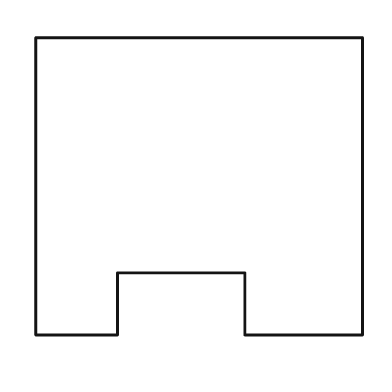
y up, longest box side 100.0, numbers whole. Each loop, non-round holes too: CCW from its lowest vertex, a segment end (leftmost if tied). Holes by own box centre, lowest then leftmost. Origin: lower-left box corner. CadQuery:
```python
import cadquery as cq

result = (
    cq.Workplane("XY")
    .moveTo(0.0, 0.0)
    .lineTo(25.0, 0.0)
    .lineTo(25.0, 19.0)
    .lineTo(64.0, 19.0)
    .lineTo(64.0, 0.0)
    .lineTo(100.0, 0.0)
    .lineTo(100.0, 91.0)
    .lineTo(0.0, 91.0)
    .close()
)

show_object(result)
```